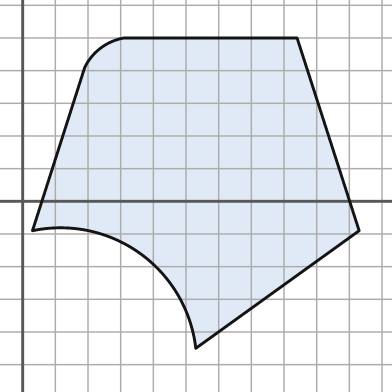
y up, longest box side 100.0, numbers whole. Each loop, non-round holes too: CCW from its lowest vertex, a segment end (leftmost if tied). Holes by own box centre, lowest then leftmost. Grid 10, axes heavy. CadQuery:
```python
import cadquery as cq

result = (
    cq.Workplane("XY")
    .moveTo(53.0, -45.0)
    .lineTo(103.0, -9.0)
    .lineTo(84.0, 50.0)
    .lineTo(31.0, 50.0)
    .threePointArc((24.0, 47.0), (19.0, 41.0))
    .lineTo(3.0, -9.0)
    .threePointArc((36.0, -16.0), (53.0, -45.0))
    .close()
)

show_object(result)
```